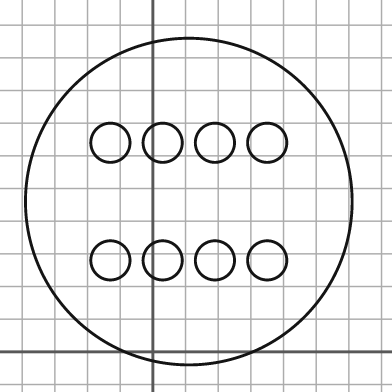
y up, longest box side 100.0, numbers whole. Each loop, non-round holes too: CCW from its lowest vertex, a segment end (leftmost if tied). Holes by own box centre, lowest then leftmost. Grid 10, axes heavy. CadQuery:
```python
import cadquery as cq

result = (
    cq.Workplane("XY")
    .moveTo(11.0, 46.0)
    .circle(50.0)
    .moveTo(-13.0, 28.0)
    .circle(6.0)
    .moveTo(3.0, 28.0)
    .circle(6.0)
    .moveTo(19.0, 28.0)
    .circle(6.0)
    .moveTo(35.0, 28.0)
    .circle(6.0)
    .moveTo(-13.0, 64.0)
    .circle(6.0)
    .moveTo(3.0, 64.0)
    .circle(6.0)
    .moveTo(19.0, 64.0)
    .circle(6.0)
    .moveTo(35.0, 64.0)
    .circle(6.0)
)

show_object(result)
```